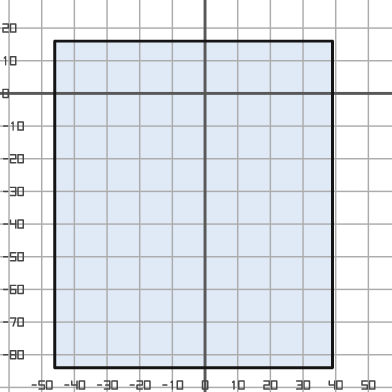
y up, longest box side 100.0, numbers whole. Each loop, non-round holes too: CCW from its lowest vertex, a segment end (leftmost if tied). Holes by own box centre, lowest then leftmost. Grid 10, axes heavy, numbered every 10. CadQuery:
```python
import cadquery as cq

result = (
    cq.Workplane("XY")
    .moveTo(-46.0, -84.0)
    .lineTo(39.0, -84.0)
    .lineTo(39.0, 16.0)
    .lineTo(-46.0, 16.0)
    .close()
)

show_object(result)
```